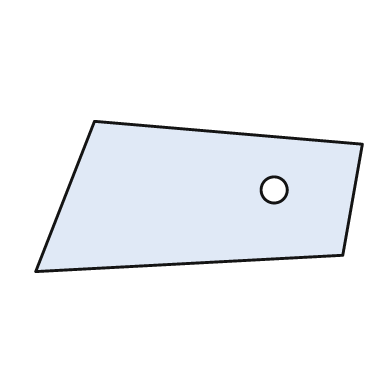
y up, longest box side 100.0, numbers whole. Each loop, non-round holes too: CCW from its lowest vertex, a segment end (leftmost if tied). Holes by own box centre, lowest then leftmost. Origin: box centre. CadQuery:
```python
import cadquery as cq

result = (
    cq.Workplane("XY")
    .moveTo(-50.0, -23.0)
    .lineTo(44.0, -18.0)
    .lineTo(50.0, 16.0)
    .lineTo(-32.0, 23.0)
    .close()
    .moveTo(23.0, 2.0)
    .circle(4.0)
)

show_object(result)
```